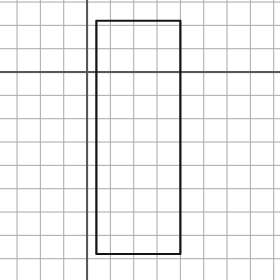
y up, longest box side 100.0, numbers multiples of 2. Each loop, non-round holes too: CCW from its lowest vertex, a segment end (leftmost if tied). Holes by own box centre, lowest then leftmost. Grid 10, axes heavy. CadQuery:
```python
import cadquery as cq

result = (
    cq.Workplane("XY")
    .moveTo(4.0, -78.0)
    .lineTo(40.0, -78.0)
    .lineTo(40.0, 22.0)
    .lineTo(4.0, 22.0)
    .close()
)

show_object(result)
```